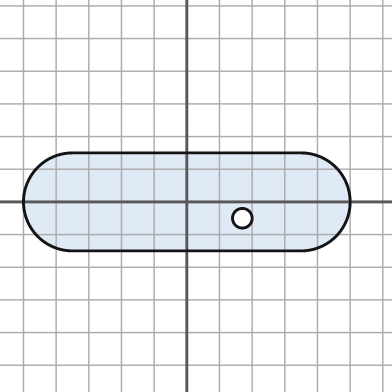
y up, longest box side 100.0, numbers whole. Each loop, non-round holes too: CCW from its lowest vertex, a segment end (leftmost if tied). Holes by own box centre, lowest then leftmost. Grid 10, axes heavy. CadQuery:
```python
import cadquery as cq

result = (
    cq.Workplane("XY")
    .moveTo(-35.0, -15.0)
    .lineTo(35.0, -15.0)
    .threePointArc((50.0, 0.0), (35.0, 15.0))
    .lineTo(-35.0, 15.0)
    .threePointArc((-50.0, 0.0), (-35.0, -15.0))
    .close()
    .moveTo(17.0, -5.0)
    .circle(3.0)
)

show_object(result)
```